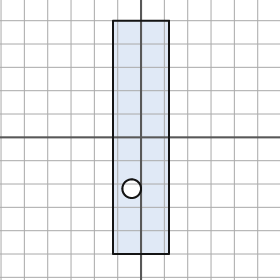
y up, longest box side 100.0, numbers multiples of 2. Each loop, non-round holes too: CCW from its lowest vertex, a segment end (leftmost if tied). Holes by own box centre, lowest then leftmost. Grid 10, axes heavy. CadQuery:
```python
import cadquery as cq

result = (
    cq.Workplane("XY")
    .moveTo(-12.0, -50.0)
    .lineTo(12.0, -50.0)
    .lineTo(12.0, 50.0)
    .lineTo(-12.0, 50.0)
    .close()
    .moveTo(-4.0, -22.0)
    .circle(4.0)
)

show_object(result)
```